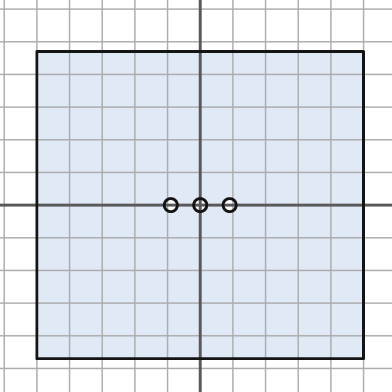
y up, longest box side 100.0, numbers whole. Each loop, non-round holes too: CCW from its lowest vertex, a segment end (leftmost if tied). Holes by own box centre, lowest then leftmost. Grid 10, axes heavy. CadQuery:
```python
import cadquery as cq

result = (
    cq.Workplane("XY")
    .moveTo(-50.0, -47.0)
    .lineTo(50.0, -47.0)
    .lineTo(50.0, 47.0)
    .lineTo(-50.0, 47.0)
    .close()
    .moveTo(-9.0, 0.0)
    .circle(2.0)
    .moveTo(0.0, 0.0)
    .circle(2.0)
    .moveTo(9.0, 0.0)
    .circle(2.0)
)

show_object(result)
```